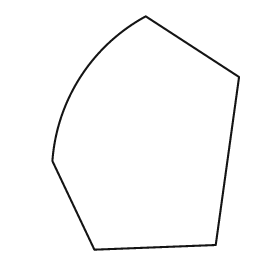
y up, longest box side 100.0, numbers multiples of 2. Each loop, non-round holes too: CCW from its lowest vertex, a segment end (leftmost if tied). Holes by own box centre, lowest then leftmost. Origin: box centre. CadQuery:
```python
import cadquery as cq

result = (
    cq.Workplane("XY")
    .moveTo(-22.0, -50.0)
    .lineTo(30.0, -48.0)
    .lineTo(40.0, 24.0)
    .lineTo(0.0, 50.0)
    .threePointArc((-28.0, 24.0), (-40.0, -12.0))
    .close()
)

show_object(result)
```